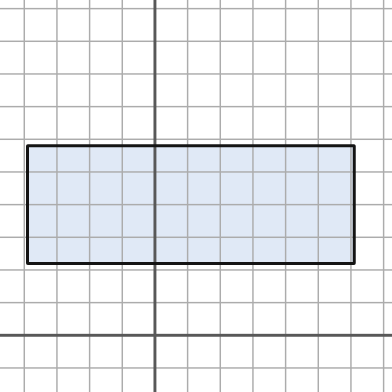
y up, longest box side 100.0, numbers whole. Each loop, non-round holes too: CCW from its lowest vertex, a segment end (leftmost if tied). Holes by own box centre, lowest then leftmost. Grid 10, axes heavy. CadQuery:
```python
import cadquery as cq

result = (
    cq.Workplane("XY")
    .moveTo(-39.0, 22.0)
    .lineTo(61.0, 22.0)
    .lineTo(61.0, 58.0)
    .lineTo(-39.0, 58.0)
    .close()
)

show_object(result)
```